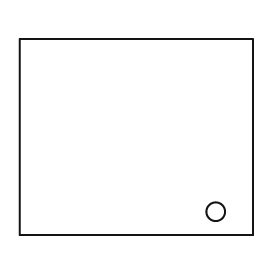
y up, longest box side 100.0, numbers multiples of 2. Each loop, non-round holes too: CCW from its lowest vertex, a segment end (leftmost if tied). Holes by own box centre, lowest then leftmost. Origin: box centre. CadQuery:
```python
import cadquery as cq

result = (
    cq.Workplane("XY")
    .moveTo(-50.0, -42.0)
    .lineTo(50.0, -42.0)
    .lineTo(50.0, 42.0)
    .lineTo(-50.0, 42.0)
    .close()
    .moveTo(34.0, -32.0)
    .circle(4.0)
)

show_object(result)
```